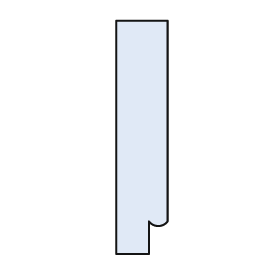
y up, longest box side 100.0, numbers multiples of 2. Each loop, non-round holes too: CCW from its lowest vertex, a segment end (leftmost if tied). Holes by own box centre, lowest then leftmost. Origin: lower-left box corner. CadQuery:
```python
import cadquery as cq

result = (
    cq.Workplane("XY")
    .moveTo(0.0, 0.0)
    .lineTo(14.0, 0.0)
    .lineTo(14.0, 14.0)
    .threePointArc((18.0, 12.0), (22.0, 14.0))
    .lineTo(22.0, 100.0)
    .lineTo(0.0, 100.0)
    .close()
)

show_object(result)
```